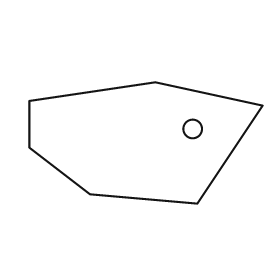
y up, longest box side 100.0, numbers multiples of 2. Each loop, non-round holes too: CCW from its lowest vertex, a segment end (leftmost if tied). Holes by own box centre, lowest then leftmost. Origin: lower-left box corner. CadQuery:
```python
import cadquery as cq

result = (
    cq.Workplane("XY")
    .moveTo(72.0, 0.0)
    .lineTo(100.0, 42.0)
    .lineTo(54.0, 52.0)
    .lineTo(0.0, 44.0)
    .lineTo(0.0, 24.0)
    .lineTo(26.0, 4.0)
    .close()
    .moveTo(70.0, 32.0)
    .circle(4.0)
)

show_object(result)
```